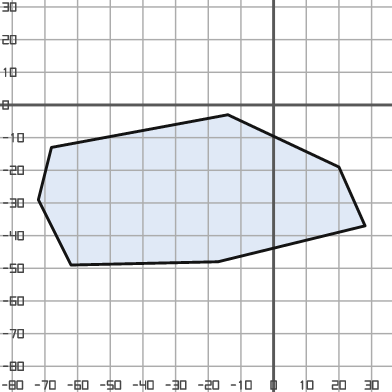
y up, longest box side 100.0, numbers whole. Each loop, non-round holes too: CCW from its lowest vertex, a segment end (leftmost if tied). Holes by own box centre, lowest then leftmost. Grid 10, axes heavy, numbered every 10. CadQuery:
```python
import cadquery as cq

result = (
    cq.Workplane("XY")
    .moveTo(-62.0, -49.0)
    .lineTo(-17.0, -48.0)
    .lineTo(28.0, -37.0)
    .lineTo(20.0, -19.0)
    .lineTo(-14.0, -3.0)
    .lineTo(-68.0, -13.0)
    .lineTo(-72.0, -29.0)
    .close()
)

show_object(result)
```